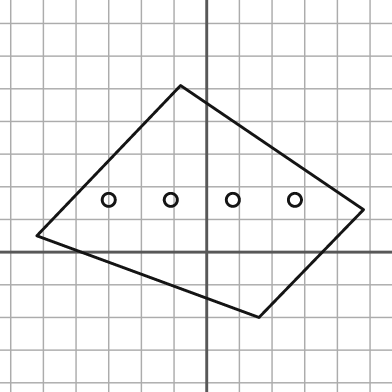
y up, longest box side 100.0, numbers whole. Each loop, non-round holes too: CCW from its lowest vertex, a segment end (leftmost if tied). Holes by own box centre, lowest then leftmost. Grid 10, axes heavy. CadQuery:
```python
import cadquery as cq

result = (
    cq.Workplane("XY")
    .moveTo(16.0, -20.0)
    .lineTo(48.0, 13.0)
    .lineTo(-8.0, 51.0)
    .lineTo(-52.0, 5.0)
    .close()
    .moveTo(-30.0, 16.0)
    .circle(2.0)
    .moveTo(-11.0, 16.0)
    .circle(2.0)
    .moveTo(8.0, 16.0)
    .circle(2.0)
    .moveTo(27.0, 16.0)
    .circle(2.0)
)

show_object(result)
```